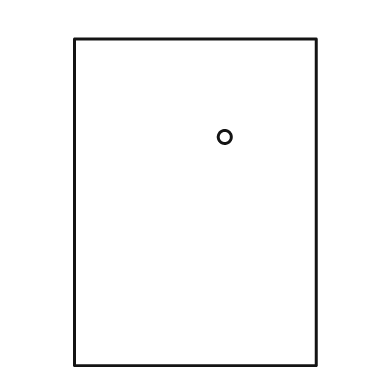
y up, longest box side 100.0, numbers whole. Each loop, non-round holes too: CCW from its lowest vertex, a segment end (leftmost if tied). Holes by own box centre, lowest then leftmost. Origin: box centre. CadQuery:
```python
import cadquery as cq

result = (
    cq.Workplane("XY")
    .moveTo(-37.0, -50.0)
    .lineTo(37.0, -50.0)
    .lineTo(37.0, 50.0)
    .lineTo(-37.0, 50.0)
    .close()
    .moveTo(9.0, 20.0)
    .circle(2.0)
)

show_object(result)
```